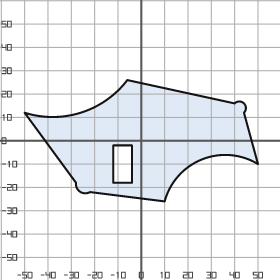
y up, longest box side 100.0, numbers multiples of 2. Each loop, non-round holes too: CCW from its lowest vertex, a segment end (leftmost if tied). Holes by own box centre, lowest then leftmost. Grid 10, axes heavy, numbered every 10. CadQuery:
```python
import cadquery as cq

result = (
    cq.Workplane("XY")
    .moveTo(10.0, -26.0)
    .threePointArc((26.0, -8.0), (50.0, -10.0))
    .lineTo(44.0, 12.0)
    .threePointArc((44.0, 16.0), (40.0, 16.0))
    .lineTo(-6.0, 26.0)
    .threePointArc((-26.0, 12.0), (-50.0, 12.0))
    .lineTo(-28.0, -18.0)
    .threePointArc((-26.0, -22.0), (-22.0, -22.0))
    .close()
    .moveTo(-12.0, -18.0)
    .lineTo(-4.0, -18.0)
    .lineTo(-4.0, -2.0)
    .lineTo(-12.0, -2.0)
    .close()
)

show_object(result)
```